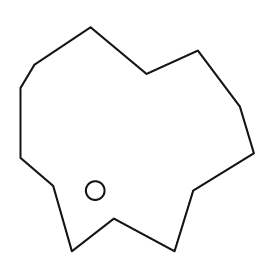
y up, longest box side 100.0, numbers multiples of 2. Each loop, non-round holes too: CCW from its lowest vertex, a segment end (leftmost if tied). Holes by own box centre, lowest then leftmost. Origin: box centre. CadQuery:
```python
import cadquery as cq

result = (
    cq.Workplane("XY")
    .moveTo(-28.0, -48.0)
    .lineTo(-10.0, -34.0)
    .lineTo(16.0, -48.0)
    .lineTo(24.0, -22.0)
    .lineTo(50.0, -6.0)
    .lineTo(44.0, 14.0)
    .lineTo(26.0, 38.0)
    .lineTo(4.0, 28.0)
    .lineTo(-20.0, 48.0)
    .lineTo(-44.0, 32.0)
    .lineTo(-50.0, 22.0)
    .lineTo(-50.0, -8.0)
    .lineTo(-36.0, -20.0)
    .close()
    .moveTo(-18.0, -22.0)
    .circle(4.0)
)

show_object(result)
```